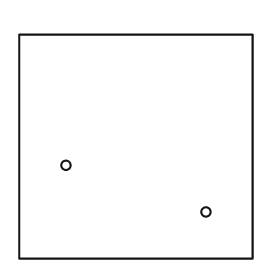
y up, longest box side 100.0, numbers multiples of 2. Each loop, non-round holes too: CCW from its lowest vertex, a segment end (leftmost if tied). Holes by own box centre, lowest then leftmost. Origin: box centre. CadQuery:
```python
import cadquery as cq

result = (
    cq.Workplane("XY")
    .moveTo(-50.0, -48.0)
    .lineTo(50.0, -48.0)
    .lineTo(50.0, 48.0)
    .lineTo(-50.0, 48.0)
    .close()
    .moveTo(30.0, -28.0)
    .circle(2.0)
    .moveTo(-30.0, -8.0)
    .circle(2.0)
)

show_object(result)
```